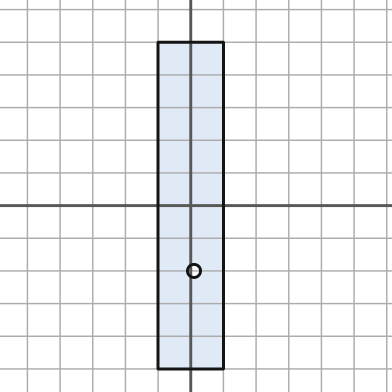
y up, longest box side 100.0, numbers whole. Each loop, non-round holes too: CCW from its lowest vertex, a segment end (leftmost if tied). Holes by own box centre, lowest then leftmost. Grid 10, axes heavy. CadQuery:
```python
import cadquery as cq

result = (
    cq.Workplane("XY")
    .moveTo(-10.0, -50.0)
    .lineTo(10.0, -50.0)
    .lineTo(10.0, 50.0)
    .lineTo(-10.0, 50.0)
    .close()
    .moveTo(1.0, -20.0)
    .circle(2.0)
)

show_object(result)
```